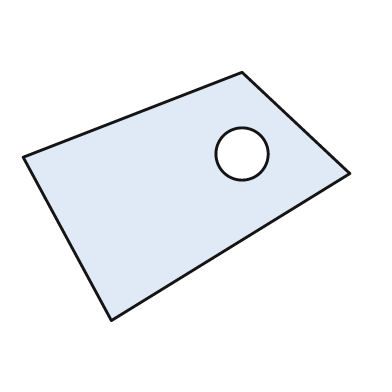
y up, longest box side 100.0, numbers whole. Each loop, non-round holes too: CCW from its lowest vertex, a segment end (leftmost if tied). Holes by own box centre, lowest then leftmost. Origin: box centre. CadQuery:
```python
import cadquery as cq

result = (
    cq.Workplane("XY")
    .moveTo(-23.0, -38.0)
    .lineTo(50.0, 7.0)
    .lineTo(17.0, 38.0)
    .lineTo(-50.0, 12.0)
    .close()
    .moveTo(17.0, 13.0)
    .circle(8.0)
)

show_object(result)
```